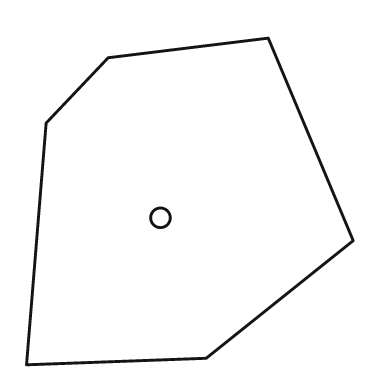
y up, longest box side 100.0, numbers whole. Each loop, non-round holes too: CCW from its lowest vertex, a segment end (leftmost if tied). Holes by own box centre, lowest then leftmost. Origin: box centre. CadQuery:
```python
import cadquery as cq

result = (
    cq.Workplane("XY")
    .moveTo(-50.0, -50.0)
    .lineTo(5.0, -48.0)
    .lineTo(50.0, -12.0)
    .lineTo(24.0, 50.0)
    .lineTo(-25.0, 44.0)
    .lineTo(-44.0, 24.0)
    .close()
    .moveTo(-9.0, -5.0)
    .circle(3.0)
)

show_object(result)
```